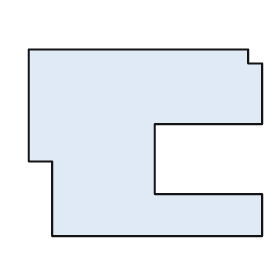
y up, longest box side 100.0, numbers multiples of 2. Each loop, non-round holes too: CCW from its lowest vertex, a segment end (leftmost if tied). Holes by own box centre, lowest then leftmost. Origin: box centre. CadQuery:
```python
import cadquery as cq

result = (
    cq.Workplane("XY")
    .moveTo(-40.0, -40.0)
    .lineTo(50.0, -40.0)
    .lineTo(50.0, -22.0)
    .lineTo(4.0, -22.0)
    .lineTo(4.0, 8.0)
    .lineTo(50.0, 8.0)
    .lineTo(50.0, 34.0)
    .lineTo(44.0, 34.0)
    .lineTo(44.0, 40.0)
    .lineTo(-50.0, 40.0)
    .lineTo(-50.0, -8.0)
    .lineTo(-40.0, -8.0)
    .close()
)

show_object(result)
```